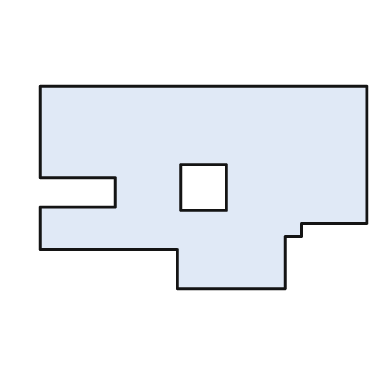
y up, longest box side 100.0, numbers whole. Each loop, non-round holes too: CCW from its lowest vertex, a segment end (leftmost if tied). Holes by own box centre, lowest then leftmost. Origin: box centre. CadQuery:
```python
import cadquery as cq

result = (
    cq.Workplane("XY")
    .moveTo(-8.0, -31.0)
    .lineTo(25.0, -31.0)
    .lineTo(25.0, -15.0)
    .lineTo(30.0, -15.0)
    .lineTo(30.0, -11.0)
    .lineTo(50.0, -11.0)
    .lineTo(50.0, 31.0)
    .lineTo(-50.0, 31.0)
    .lineTo(-50.0, 3.0)
    .lineTo(-27.0, 3.0)
    .lineTo(-27.0, -6.0)
    .lineTo(-50.0, -6.0)
    .lineTo(-50.0, -19.0)
    .lineTo(-8.0, -19.0)
    .close()
    .moveTo(-7.0, -7.0)
    .lineTo(7.0, -7.0)
    .lineTo(7.0, 7.0)
    .lineTo(-7.0, 7.0)
    .close()
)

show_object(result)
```